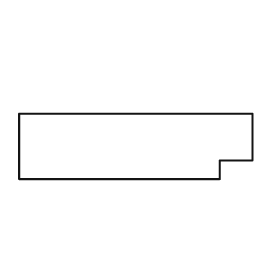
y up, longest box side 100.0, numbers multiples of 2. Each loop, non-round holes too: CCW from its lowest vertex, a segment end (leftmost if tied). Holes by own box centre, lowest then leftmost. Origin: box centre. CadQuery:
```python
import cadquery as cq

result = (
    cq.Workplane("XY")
    .moveTo(-50.0, -14.0)
    .lineTo(36.0, -14.0)
    .lineTo(36.0, -6.0)
    .lineTo(50.0, -6.0)
    .lineTo(50.0, 14.0)
    .lineTo(-50.0, 14.0)
    .close()
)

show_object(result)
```